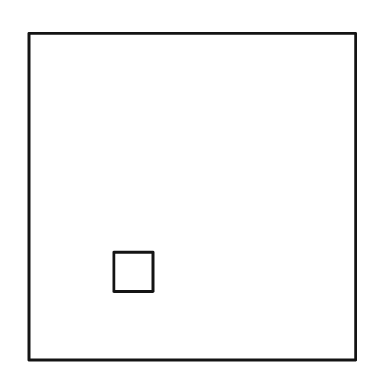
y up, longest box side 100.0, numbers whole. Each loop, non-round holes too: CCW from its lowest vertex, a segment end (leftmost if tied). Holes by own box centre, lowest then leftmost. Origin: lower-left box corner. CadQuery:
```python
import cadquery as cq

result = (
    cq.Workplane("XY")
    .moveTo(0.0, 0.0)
    .lineTo(100.0, 0.0)
    .lineTo(100.0, 100.0)
    .lineTo(0.0, 100.0)
    .close()
    .moveTo(26.0, 21.0)
    .lineTo(38.0, 21.0)
    .lineTo(38.0, 33.0)
    .lineTo(26.0, 33.0)
    .close()
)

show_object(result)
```